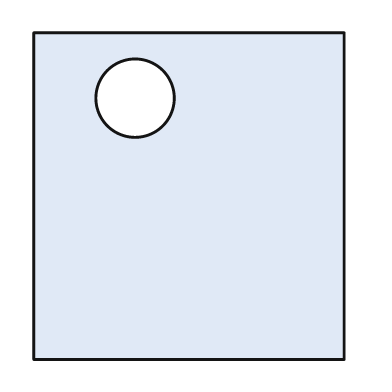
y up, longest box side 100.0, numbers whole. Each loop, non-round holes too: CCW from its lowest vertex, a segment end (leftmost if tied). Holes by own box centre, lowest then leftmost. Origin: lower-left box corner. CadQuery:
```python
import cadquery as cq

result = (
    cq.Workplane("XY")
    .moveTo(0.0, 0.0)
    .lineTo(95.0, 0.0)
    .lineTo(95.0, 100.0)
    .lineTo(0.0, 100.0)
    .close()
    .moveTo(31.0, 80.0)
    .circle(12.0)
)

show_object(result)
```